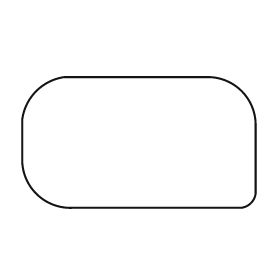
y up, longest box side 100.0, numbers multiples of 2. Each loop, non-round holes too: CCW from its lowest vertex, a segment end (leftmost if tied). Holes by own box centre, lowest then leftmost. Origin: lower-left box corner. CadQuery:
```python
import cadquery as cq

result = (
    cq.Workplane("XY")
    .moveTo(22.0, 0.0)
    .lineTo(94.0, 0.0)
    .threePointArc((98.0, 2.0), (100.0, 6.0))
    .lineTo(100.0, 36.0)
    .threePointArc((94.0, 50.0), (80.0, 56.0))
    .lineTo(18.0, 56.0)
    .threePointArc((6.0, 50.0), (0.0, 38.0))
    .lineTo(0.0, 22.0)
    .threePointArc((6.0, 6.0), (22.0, 0.0))
    .close()
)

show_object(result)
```